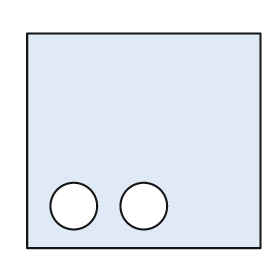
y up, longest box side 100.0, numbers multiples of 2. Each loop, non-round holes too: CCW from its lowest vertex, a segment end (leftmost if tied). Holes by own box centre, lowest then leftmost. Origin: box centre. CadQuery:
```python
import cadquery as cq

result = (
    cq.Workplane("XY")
    .moveTo(-50.0, -46.0)
    .lineTo(50.0, -46.0)
    .lineTo(50.0, 46.0)
    .lineTo(-50.0, 46.0)
    .close()
    .moveTo(-30.0, -28.0)
    .circle(10.0)
    .moveTo(0.0, -28.0)
    .circle(10.0)
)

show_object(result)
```